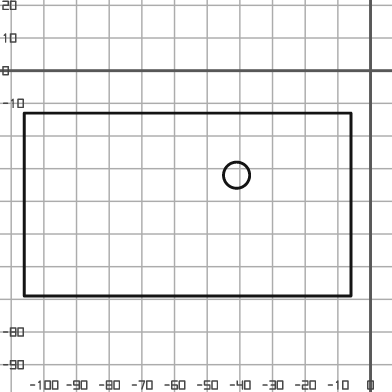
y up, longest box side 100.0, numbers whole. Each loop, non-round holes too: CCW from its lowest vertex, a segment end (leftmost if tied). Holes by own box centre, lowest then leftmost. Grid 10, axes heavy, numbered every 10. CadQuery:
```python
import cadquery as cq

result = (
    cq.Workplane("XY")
    .moveTo(-106.0, -69.0)
    .lineTo(-6.0, -69.0)
    .lineTo(-6.0, -13.0)
    .lineTo(-106.0, -13.0)
    .close()
    .moveTo(-41.0, -32.0)
    .circle(4.0)
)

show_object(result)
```